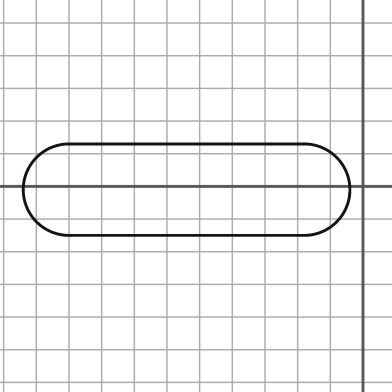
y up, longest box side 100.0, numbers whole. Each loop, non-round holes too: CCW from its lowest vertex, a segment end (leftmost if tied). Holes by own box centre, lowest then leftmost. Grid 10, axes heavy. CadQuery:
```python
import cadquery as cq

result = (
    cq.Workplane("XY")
    .moveTo(-90.0, -15.0)
    .lineTo(-18.0, -15.0)
    .threePointArc((-4.0, -1.0), (-18.0, 13.0))
    .lineTo(-90.0, 13.0)
    .threePointArc((-104.0, -1.0), (-90.0, -15.0))
    .close()
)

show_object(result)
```